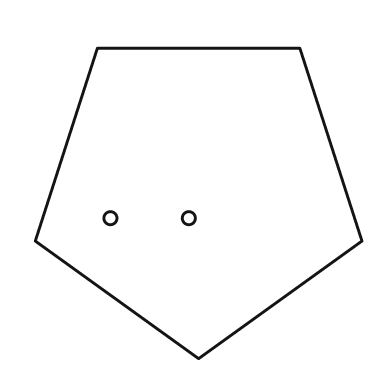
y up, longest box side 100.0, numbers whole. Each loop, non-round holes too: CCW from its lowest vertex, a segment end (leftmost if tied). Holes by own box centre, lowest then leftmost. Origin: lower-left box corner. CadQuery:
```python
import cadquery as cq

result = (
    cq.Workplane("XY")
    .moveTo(50.0, 0.0)
    .lineTo(100.0, 36.0)
    .lineTo(81.0, 95.0)
    .lineTo(19.0, 95.0)
    .lineTo(0.0, 36.0)
    .close()
    .moveTo(23.0, 43.0)
    .circle(2.0)
    .moveTo(47.0, 43.0)
    .circle(2.0)
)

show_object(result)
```